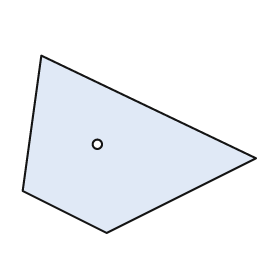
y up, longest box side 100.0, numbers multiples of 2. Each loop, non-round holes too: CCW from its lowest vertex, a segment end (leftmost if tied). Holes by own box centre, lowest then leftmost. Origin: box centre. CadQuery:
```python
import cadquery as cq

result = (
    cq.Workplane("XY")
    .moveTo(-14.0, -38.0)
    .lineTo(50.0, -6.0)
    .lineTo(-42.0, 38.0)
    .lineTo(-50.0, -20.0)
    .close()
    .moveTo(-18.0, 0.0)
    .circle(2.0)
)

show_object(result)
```